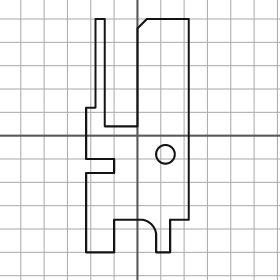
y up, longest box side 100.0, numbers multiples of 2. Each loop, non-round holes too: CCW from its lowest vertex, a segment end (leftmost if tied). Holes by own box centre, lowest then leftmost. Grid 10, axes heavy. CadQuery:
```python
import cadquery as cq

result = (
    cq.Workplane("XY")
    .moveTo(-22.0, -50.0)
    .lineTo(-10.0, -50.0)
    .lineTo(-10.0, -36.0)
    .lineTo(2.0, -36.0)
    .threePointArc((6.0, -38.0), (8.0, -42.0))
    .lineTo(8.0, -50.0)
    .lineTo(14.0, -50.0)
    .lineTo(14.0, -36.0)
    .lineTo(22.0, -36.0)
    .lineTo(22.0, 50.0)
    .lineTo(4.0, 50.0)
    .lineTo(0.0, 46.0)
    .lineTo(0.0, 4.0)
    .lineTo(-14.0, 4.0)
    .lineTo(-14.0, 50.0)
    .lineTo(-18.0, 50.0)
    .lineTo(-18.0, 12.0)
    .lineTo(-22.0, 12.0)
    .lineTo(-22.0, -10.0)
    .lineTo(-10.0, -10.0)
    .lineTo(-10.0, -16.0)
    .lineTo(-22.0, -16.0)
    .close()
    .moveTo(12.0, -8.0)
    .circle(4.0)
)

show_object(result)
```